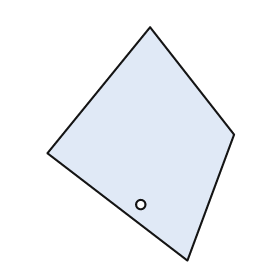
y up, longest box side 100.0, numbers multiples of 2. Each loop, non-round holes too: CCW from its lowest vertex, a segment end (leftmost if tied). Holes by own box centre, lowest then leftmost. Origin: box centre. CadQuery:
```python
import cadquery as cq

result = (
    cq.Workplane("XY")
    .moveTo(20.0, -50.0)
    .lineTo(40.0, 4.0)
    .lineTo(4.0, 50.0)
    .lineTo(-40.0, -4.0)
    .close()
    .moveTo(0.0, -26.0)
    .circle(2.0)
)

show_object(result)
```